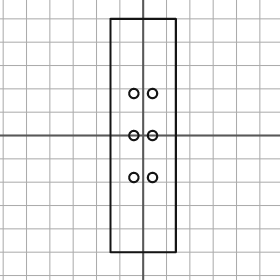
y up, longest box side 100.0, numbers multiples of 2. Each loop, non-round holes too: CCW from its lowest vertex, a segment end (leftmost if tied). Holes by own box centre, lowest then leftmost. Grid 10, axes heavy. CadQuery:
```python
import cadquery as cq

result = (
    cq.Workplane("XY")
    .moveTo(-14.0, -50.0)
    .lineTo(14.0, -50.0)
    .lineTo(14.0, 50.0)
    .lineTo(-14.0, 50.0)
    .close()
    .moveTo(-4.0, -18.0)
    .circle(2.0)
    .moveTo(4.0, -18.0)
    .circle(2.0)
    .moveTo(-4.0, 0.0)
    .circle(2.0)
    .moveTo(4.0, 0.0)
    .circle(2.0)
    .moveTo(-4.0, 18.0)
    .circle(2.0)
    .moveTo(4.0, 18.0)
    .circle(2.0)
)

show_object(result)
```